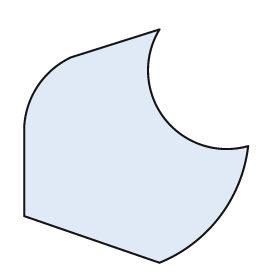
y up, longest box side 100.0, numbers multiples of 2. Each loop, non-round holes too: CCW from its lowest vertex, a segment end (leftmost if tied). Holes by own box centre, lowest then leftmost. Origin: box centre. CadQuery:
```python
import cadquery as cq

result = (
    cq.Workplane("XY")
    .moveTo(10.0, -50.0)
    .threePointArc((36.0, -30.0), (48.0, 0.0))
    .threePointArc((12.0, 12.0), (10.0, 50.0))
    .lineTo(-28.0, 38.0)
    .threePointArc((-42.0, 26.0), (-48.0, 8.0))
    .lineTo(-48.0, -30.0)
    .close()
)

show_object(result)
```